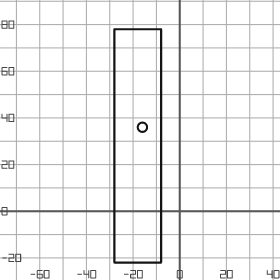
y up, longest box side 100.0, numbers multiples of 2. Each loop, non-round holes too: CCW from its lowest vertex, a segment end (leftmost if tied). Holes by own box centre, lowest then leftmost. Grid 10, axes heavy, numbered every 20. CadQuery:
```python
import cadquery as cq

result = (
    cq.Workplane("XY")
    .moveTo(-28.0, -22.0)
    .lineTo(-8.0, -22.0)
    .lineTo(-8.0, 78.0)
    .lineTo(-28.0, 78.0)
    .close()
    .moveTo(-16.0, 36.0)
    .circle(2.0)
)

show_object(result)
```